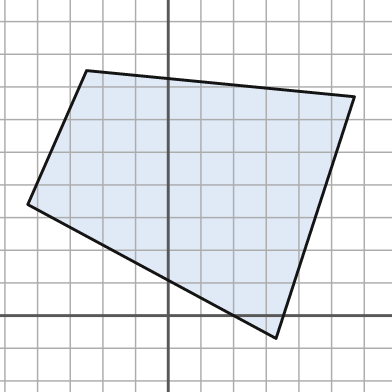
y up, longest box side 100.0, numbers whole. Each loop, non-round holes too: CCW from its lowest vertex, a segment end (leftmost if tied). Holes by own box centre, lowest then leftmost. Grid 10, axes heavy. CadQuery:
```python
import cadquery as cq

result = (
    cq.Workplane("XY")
    .moveTo(33.0, -7.0)
    .lineTo(57.0, 67.0)
    .lineTo(-25.0, 75.0)
    .lineTo(-43.0, 34.0)
    .close()
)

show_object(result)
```